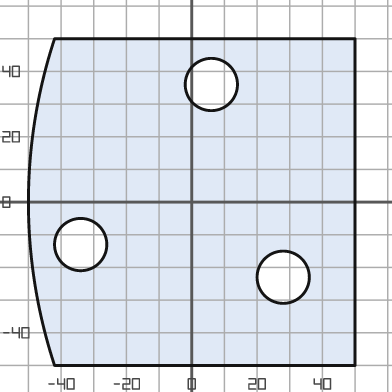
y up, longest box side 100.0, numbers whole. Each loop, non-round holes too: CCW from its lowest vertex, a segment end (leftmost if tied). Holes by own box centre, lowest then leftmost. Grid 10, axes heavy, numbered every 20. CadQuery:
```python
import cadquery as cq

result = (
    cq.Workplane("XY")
    .moveTo(-42.0, -50.0)
    .lineTo(50.0, -50.0)
    .lineTo(50.0, 50.0)
    .lineTo(-42.0, 50.0)
    .threePointArc((-50.0, 0.0), (-42.0, -50.0))
    .close()
    .moveTo(28.0, -23.0)
    .circle(8.0)
    .moveTo(-34.0, -13.0)
    .circle(8.0)
    .moveTo(6.0, 36.0)
    .circle(8.0)
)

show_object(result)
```